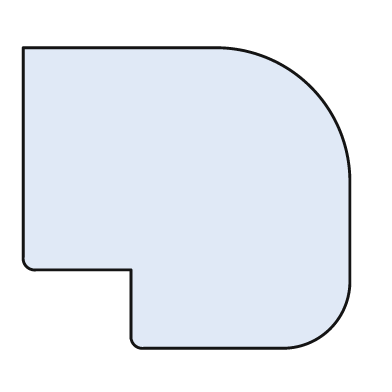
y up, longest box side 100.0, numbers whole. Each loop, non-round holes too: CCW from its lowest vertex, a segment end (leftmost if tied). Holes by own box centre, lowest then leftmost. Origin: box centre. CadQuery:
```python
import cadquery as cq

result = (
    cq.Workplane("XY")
    .moveTo(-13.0, -46.0)
    .lineTo(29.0, -46.0)
    .threePointArc((44.0, -40.0), (50.0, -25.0))
    .lineTo(50.0, 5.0)
    .threePointArc((38.0, 34.0), (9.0, 46.0))
    .lineTo(-50.0, 46.0)
    .lineTo(-50.0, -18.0)
    .threePointArc((-49.0, -21.0), (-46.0, -22.0))
    .lineTo(-17.0, -22.0)
    .lineTo(-17.0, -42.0)
    .threePointArc((-16.0, -45.0), (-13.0, -46.0))
    .close()
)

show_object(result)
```